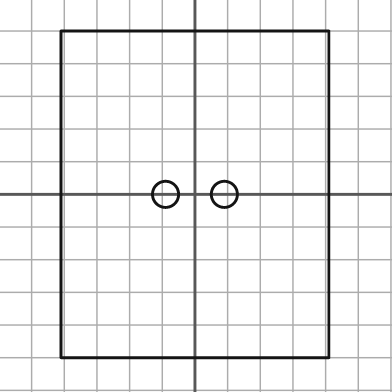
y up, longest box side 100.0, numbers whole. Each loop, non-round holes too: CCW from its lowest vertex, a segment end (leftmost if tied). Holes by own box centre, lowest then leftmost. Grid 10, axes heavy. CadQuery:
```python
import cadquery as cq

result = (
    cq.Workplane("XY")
    .moveTo(-41.0, -50.0)
    .lineTo(41.0, -50.0)
    .lineTo(41.0, 50.0)
    .lineTo(-41.0, 50.0)
    .close()
    .moveTo(-9.0, 0.0)
    .circle(4.0)
    .moveTo(9.0, 0.0)
    .circle(4.0)
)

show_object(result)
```